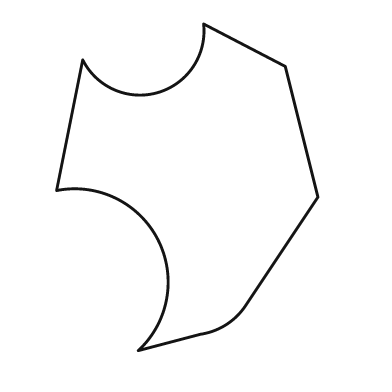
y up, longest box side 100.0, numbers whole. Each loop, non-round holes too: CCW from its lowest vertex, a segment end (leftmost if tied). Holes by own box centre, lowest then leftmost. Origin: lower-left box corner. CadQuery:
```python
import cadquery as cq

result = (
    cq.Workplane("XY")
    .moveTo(25.0, 0.0)
    .lineTo(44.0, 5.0)
    .threePointArc((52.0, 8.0), (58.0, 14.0))
    .lineTo(80.0, 47.0)
    .lineTo(70.0, 87.0)
    .lineTo(45.0, 100.0)
    .threePointArc((31.0, 79.0), (8.0, 89.0))
    .lineTo(0.0, 49.0)
    .threePointArc((31.0, 34.0), (25.0, 0.0))
    .close()
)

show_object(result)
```